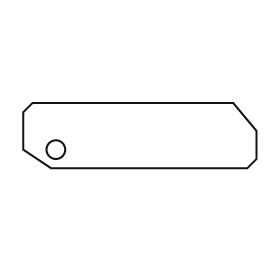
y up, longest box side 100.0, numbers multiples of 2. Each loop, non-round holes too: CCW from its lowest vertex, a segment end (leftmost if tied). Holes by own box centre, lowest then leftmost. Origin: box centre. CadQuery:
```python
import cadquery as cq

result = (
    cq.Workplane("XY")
    .moveTo(-38.0, -14.0)
    .lineTo(46.0, -14.0)
    .lineTo(50.0, -10.0)
    .lineTo(50.0, 2.0)
    .lineTo(40.0, 14.0)
    .lineTo(-46.0, 14.0)
    .lineTo(-50.0, 10.0)
    .lineTo(-50.0, -6.0)
    .close()
    .moveTo(-36.0, -6.0)
    .circle(4.0)
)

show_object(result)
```